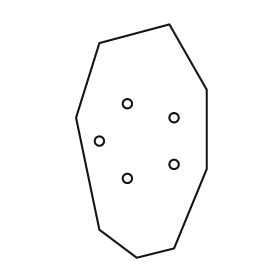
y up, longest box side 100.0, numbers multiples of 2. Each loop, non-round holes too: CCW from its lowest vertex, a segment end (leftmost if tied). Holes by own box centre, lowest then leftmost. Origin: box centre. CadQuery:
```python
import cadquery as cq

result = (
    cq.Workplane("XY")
    .moveTo(-2.0, -50.0)
    .lineTo(14.0, -46.0)
    .lineTo(28.0, -12.0)
    .lineTo(28.0, 22.0)
    .lineTo(12.0, 50.0)
    .lineTo(-18.0, 42.0)
    .lineTo(-28.0, 10.0)
    .lineTo(-18.0, -38.0)
    .close()
    .moveTo(-6.0, -16.0)
    .circle(2.0)
    .moveTo(14.0, -10.0)
    .circle(2.0)
    .moveTo(-18.0, 0.0)
    .circle(2.0)
    .moveTo(14.0, 10.0)
    .circle(2.0)
    .moveTo(-6.0, 16.0)
    .circle(2.0)
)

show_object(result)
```